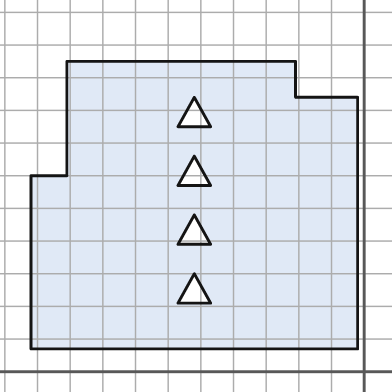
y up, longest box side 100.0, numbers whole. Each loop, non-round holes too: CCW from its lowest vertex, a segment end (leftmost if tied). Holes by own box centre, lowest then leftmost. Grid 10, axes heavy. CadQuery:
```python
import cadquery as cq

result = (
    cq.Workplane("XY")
    .moveTo(-102.0, 7.0)
    .lineTo(-2.0, 7.0)
    .lineTo(-2.0, 84.0)
    .lineTo(-21.0, 84.0)
    .lineTo(-21.0, 95.0)
    .lineTo(-91.0, 95.0)
    .lineTo(-91.0, 60.0)
    .lineTo(-102.0, 60.0)
    .close()
    .moveTo(-57.0, 21.0)
    .lineTo(-47.0, 21.0)
    .lineTo(-52.0, 30.0)
    .close()
    .moveTo(-57.0, 39.0)
    .lineTo(-47.0, 39.0)
    .lineTo(-52.0, 48.0)
    .close()
    .moveTo(-57.0, 57.0)
    .lineTo(-47.0, 57.0)
    .lineTo(-52.0, 66.0)
    .close()
    .moveTo(-57.0, 75.0)
    .lineTo(-47.0, 75.0)
    .lineTo(-52.0, 84.0)
    .close()
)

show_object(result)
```